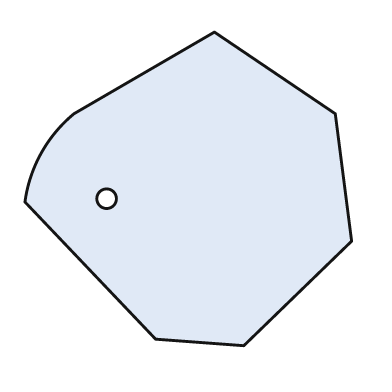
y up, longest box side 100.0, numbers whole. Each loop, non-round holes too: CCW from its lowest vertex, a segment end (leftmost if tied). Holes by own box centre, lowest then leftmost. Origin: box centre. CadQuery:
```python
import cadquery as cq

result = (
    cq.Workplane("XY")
    .moveTo(17.0, -48.0)
    .lineTo(50.0, -16.0)
    .lineTo(45.0, 23.0)
    .lineTo(8.0, 48.0)
    .lineTo(-35.0, 23.0)
    .threePointArc((-45.0, 11.0), (-50.0, -4.0))
    .lineTo(-10.0, -46.0)
    .close()
    .moveTo(-25.0, -3.0)
    .circle(3.0)
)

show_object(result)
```